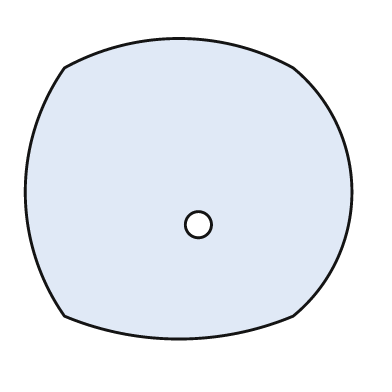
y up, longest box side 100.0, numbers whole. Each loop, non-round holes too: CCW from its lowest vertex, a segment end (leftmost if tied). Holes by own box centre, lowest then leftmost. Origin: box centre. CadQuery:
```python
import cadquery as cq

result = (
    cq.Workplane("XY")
    .moveTo(-38.0, -39.0)
    .threePointArc((-3.0, -46.0), (32.0, -39.0))
    .threePointArc((50.0, -1.0), (32.0, 37.0))
    .threePointArc((-3.0, 46.0), (-38.0, 37.0))
    .threePointArc((-50.0, -1.0), (-38.0, -39.0))
    .close()
    .moveTo(3.0, -11.0)
    .circle(4.0)
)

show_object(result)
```